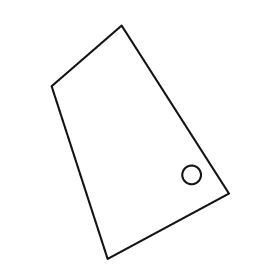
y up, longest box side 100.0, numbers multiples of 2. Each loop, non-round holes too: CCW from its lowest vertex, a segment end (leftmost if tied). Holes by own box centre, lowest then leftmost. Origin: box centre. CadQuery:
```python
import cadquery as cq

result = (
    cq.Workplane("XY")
    .moveTo(-14.0, -50.0)
    .lineTo(38.0, -22.0)
    .lineTo(-8.0, 50.0)
    .lineTo(-38.0, 24.0)
    .close()
    .moveTo(22.0, -14.0)
    .circle(4.0)
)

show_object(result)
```